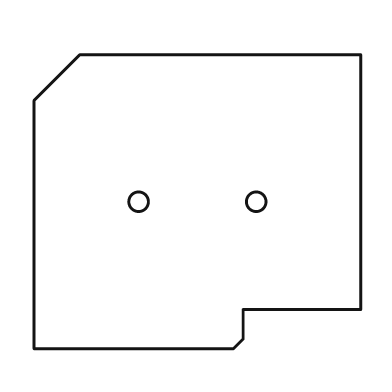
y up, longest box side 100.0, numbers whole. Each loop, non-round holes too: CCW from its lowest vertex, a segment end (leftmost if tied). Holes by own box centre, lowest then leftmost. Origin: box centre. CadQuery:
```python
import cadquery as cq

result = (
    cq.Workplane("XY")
    .moveTo(-50.0, -45.0)
    .lineTo(11.0, -45.0)
    .lineTo(14.0, -42.0)
    .lineTo(14.0, -33.0)
    .lineTo(50.0, -33.0)
    .lineTo(50.0, 45.0)
    .lineTo(-36.0, 45.0)
    .lineTo(-50.0, 31.0)
    .close()
    .moveTo(-18.0, 0.0)
    .circle(3.0)
    .moveTo(18.0, 0.0)
    .circle(3.0)
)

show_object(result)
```